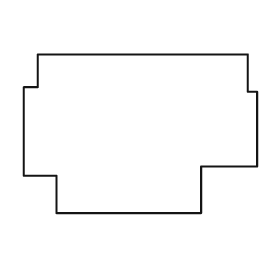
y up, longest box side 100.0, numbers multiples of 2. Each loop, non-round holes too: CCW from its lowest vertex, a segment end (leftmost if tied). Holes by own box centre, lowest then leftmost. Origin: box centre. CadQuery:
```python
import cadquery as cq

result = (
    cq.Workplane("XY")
    .moveTo(-36.0, -34.0)
    .lineTo(26.0, -34.0)
    .lineTo(26.0, -14.0)
    .lineTo(50.0, -14.0)
    .lineTo(50.0, 18.0)
    .lineTo(46.0, 18.0)
    .lineTo(46.0, 34.0)
    .lineTo(-44.0, 34.0)
    .lineTo(-44.0, 20.0)
    .lineTo(-50.0, 20.0)
    .lineTo(-50.0, -18.0)
    .lineTo(-36.0, -18.0)
    .close()
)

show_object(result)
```